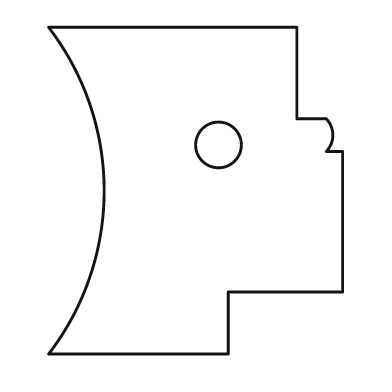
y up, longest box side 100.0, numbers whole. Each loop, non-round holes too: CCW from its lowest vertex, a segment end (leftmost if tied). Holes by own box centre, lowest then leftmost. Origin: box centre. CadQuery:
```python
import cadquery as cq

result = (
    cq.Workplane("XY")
    .moveTo(-45.0, -50.0)
    .lineTo(10.0, -50.0)
    .lineTo(10.0, -31.0)
    .lineTo(45.0, -31.0)
    .lineTo(45.0, 12.0)
    .lineTo(40.0, 12.0)
    .threePointArc((42.0, 17.0), (40.0, 22.0))
    .lineTo(31.0, 22.0)
    .lineTo(31.0, 50.0)
    .lineTo(-45.0, 50.0)
    .threePointArc((-28.0, 0.0), (-45.0, -50.0))
    .close()
    .moveTo(7.0, 14.0)
    .circle(7.0)
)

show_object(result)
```